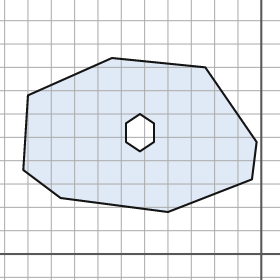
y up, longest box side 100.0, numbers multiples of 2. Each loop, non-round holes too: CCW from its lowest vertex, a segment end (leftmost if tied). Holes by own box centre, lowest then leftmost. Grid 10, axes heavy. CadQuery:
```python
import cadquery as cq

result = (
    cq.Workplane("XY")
    .moveTo(-40.0, 18.0)
    .lineTo(-4.0, 32.0)
    .lineTo(-2.0, 48.0)
    .lineTo(-24.0, 80.0)
    .lineTo(-64.0, 84.0)
    .lineTo(-100.0, 68.0)
    .lineTo(-102.0, 36.0)
    .lineTo(-86.0, 24.0)
    .close()
    .moveTo(-52.0, 44.0)
    .lineTo(-46.0, 48.0)
    .lineTo(-46.0, 56.0)
    .lineTo(-52.0, 60.0)
    .lineTo(-58.0, 56.0)
    .lineTo(-58.0, 48.0)
    .close()
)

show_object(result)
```